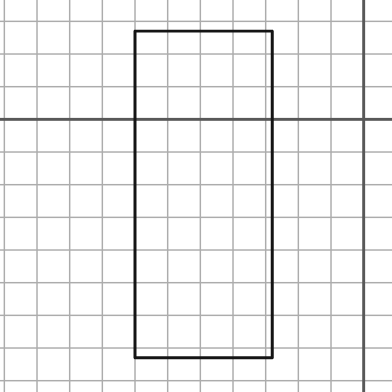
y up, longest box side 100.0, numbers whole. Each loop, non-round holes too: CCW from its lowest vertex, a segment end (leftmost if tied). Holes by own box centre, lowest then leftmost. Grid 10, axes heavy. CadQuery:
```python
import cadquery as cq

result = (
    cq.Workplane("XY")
    .moveTo(-70.0, -73.0)
    .lineTo(-28.0, -73.0)
    .lineTo(-28.0, 27.0)
    .lineTo(-70.0, 27.0)
    .close()
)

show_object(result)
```